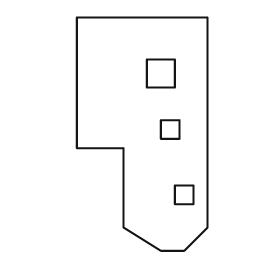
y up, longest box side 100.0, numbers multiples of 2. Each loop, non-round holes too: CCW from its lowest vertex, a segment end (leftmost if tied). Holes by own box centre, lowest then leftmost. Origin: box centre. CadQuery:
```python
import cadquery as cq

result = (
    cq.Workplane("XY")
    .moveTo(8.0, -50.0)
    .lineTo(18.0, -50.0)
    .lineTo(28.0, -40.0)
    .lineTo(28.0, 50.0)
    .lineTo(-28.0, 50.0)
    .lineTo(-28.0, -6.0)
    .lineTo(-8.0, -6.0)
    .lineTo(-8.0, -40.0)
    .close()
    .moveTo(14.0, -30.0)
    .lineTo(22.0, -30.0)
    .lineTo(22.0, -22.0)
    .lineTo(14.0, -22.0)
    .close()
    .moveTo(8.0, -2.0)
    .lineTo(16.0, -2.0)
    .lineTo(16.0, 6.0)
    .lineTo(8.0, 6.0)
    .close()
    .moveTo(2.0, 20.0)
    .lineTo(14.0, 20.0)
    .lineTo(14.0, 32.0)
    .lineTo(2.0, 32.0)
    .close()
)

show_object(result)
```